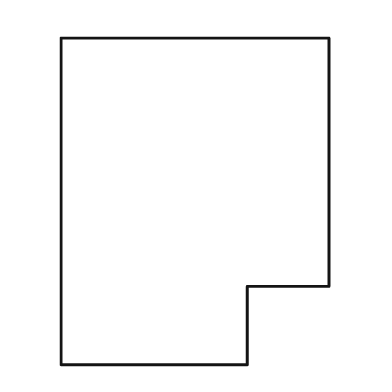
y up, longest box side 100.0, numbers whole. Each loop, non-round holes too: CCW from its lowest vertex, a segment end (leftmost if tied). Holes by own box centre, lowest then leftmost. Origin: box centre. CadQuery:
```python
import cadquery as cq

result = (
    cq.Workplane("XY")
    .moveTo(-41.0, -50.0)
    .lineTo(16.0, -50.0)
    .lineTo(16.0, -26.0)
    .lineTo(41.0, -26.0)
    .lineTo(41.0, 50.0)
    .lineTo(-41.0, 50.0)
    .close()
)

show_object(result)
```